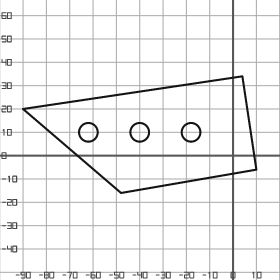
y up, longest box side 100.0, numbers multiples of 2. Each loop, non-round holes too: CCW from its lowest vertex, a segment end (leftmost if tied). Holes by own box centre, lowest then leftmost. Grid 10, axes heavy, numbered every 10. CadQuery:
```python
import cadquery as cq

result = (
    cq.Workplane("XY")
    .moveTo(-48.0, -16.0)
    .lineTo(10.0, -6.0)
    .lineTo(4.0, 34.0)
    .lineTo(-90.0, 20.0)
    .close()
    .moveTo(-62.0, 10.0)
    .circle(4.0)
    .moveTo(-40.0, 10.0)
    .circle(4.0)
    .moveTo(-18.0, 10.0)
    .circle(4.0)
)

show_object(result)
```